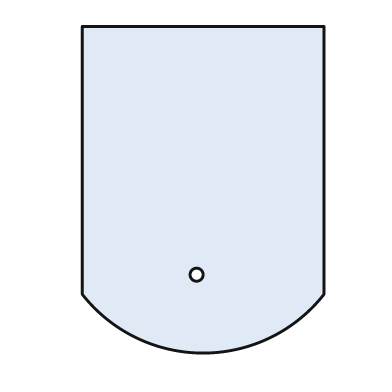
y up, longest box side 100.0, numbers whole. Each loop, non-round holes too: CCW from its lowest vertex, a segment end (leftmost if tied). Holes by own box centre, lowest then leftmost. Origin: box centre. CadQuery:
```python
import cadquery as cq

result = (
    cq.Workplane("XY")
    .moveTo(-37.0, -32.0)
    .threePointArc((0.0, -50.0), (37.0, -32.0))
    .lineTo(37.0, 50.0)
    .lineTo(-37.0, 50.0)
    .close()
    .moveTo(-2.0, -26.0)
    .circle(2.0)
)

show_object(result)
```